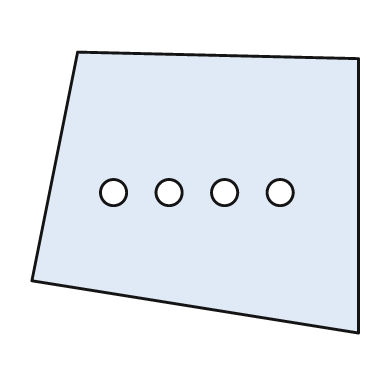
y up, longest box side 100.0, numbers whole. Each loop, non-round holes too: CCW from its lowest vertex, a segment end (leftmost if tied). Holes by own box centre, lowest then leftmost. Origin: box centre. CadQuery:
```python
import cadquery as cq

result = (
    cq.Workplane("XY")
    .moveTo(50.0, -43.0)
    .lineTo(50.0, 41.0)
    .lineTo(-36.0, 43.0)
    .lineTo(-50.0, -27.0)
    .close()
    .moveTo(-25.0, 0.0)
    .circle(4.0)
    .moveTo(-8.0, 0.0)
    .circle(4.0)
    .moveTo(9.0, 0.0)
    .circle(4.0)
    .moveTo(26.0, 0.0)
    .circle(4.0)
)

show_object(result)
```